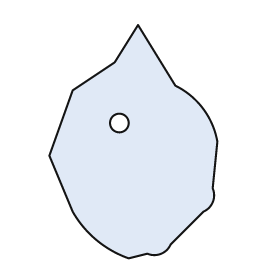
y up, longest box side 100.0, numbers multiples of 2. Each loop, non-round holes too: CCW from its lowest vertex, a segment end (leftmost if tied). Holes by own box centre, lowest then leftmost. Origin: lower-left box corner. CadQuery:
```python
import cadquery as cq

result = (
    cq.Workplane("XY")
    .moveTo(34.0, 0.0)
    .lineTo(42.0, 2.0)
    .threePointArc((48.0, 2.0), (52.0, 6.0))
    .lineTo(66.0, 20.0)
    .threePointArc((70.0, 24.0), (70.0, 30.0))
    .lineTo(72.0, 50.0)
    .threePointArc((66.0, 64.0), (54.0, 74.0))
    .lineTo(38.0, 100.0)
    .lineTo(28.0, 84.0)
    .lineTo(10.0, 72.0)
    .lineTo(0.0, 44.0)
    .lineTo(10.0, 20.0)
    .threePointArc((20.0, 8.0), (34.0, 0.0))
    .close()
    .moveTo(30.0, 58.0)
    .circle(4.0)
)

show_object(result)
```